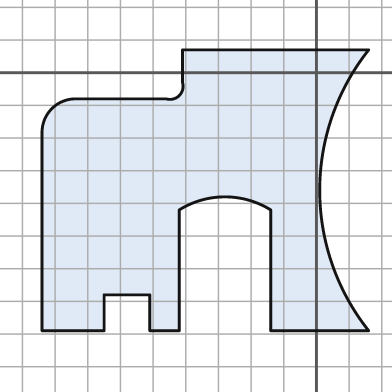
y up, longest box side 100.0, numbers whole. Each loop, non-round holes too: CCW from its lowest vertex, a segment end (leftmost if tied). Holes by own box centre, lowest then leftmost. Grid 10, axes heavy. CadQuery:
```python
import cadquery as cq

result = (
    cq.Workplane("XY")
    .moveTo(-84.0, -79.0)
    .lineTo(-65.0, -79.0)
    .lineTo(-65.0, -68.0)
    .lineTo(-51.0, -68.0)
    .lineTo(-51.0, -79.0)
    .lineTo(-42.0, -79.0)
    .lineTo(-42.0, -42.0)
    .threePointArc((-28.0, -38.0), (-14.0, -42.0))
    .lineTo(-14.0, -79.0)
    .lineTo(16.0, -79.0)
    .threePointArc((1.0, -36.0), (16.0, 7.0))
    .lineTo(-41.0, 7.0)
    .lineTo(-41.0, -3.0)
    .threePointArc((-42.0, -7.0), (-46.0, -8.0))
    .lineTo(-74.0, -8.0)
    .threePointArc((-81.0, -11.0), (-84.0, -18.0))
    .close()
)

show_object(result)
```